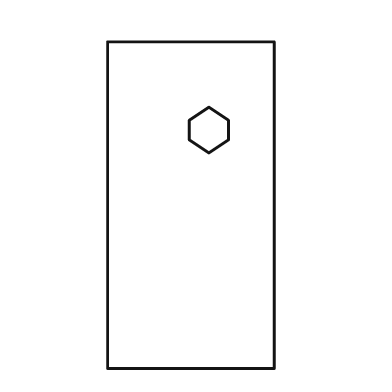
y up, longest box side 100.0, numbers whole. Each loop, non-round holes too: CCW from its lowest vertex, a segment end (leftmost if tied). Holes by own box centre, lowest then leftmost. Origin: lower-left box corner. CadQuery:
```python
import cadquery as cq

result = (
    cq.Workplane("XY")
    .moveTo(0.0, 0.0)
    .lineTo(51.0, 0.0)
    .lineTo(51.0, 100.0)
    .lineTo(0.0, 100.0)
    .close()
    .moveTo(31.0, 66.0)
    .lineTo(37.0, 70.0)
    .lineTo(37.0, 76.0)
    .lineTo(31.0, 80.0)
    .lineTo(25.0, 76.0)
    .lineTo(25.0, 70.0)
    .close()
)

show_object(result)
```